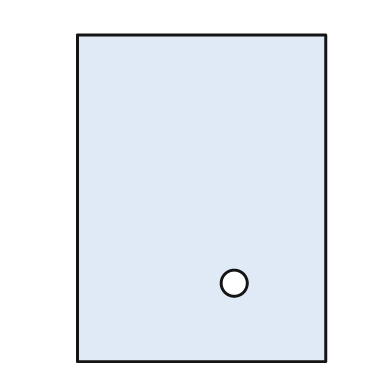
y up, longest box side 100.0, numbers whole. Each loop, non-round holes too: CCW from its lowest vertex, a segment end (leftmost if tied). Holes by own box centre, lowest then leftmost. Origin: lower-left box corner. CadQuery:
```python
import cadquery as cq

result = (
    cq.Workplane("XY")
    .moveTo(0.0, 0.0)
    .lineTo(76.0, 0.0)
    .lineTo(76.0, 100.0)
    .lineTo(0.0, 100.0)
    .close()
    .moveTo(48.0, 24.0)
    .circle(4.0)
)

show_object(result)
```